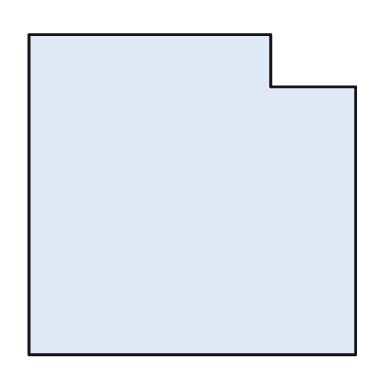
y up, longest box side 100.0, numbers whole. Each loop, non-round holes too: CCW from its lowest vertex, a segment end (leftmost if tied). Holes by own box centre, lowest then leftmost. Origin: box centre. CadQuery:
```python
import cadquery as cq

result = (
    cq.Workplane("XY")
    .moveTo(-50.0, -49.0)
    .lineTo(50.0, -49.0)
    .lineTo(50.0, 33.0)
    .lineTo(24.0, 33.0)
    .lineTo(24.0, 49.0)
    .lineTo(-50.0, 49.0)
    .close()
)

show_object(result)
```